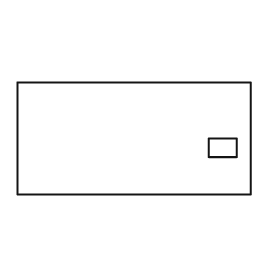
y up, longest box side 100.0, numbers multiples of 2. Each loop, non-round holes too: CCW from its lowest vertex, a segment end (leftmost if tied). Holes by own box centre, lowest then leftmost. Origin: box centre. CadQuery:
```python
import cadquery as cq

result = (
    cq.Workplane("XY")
    .moveTo(-50.0, -24.0)
    .lineTo(50.0, -24.0)
    .lineTo(50.0, 24.0)
    .lineTo(-50.0, 24.0)
    .close()
    .moveTo(32.0, -8.0)
    .lineTo(44.0, -8.0)
    .lineTo(44.0, 0.0)
    .lineTo(32.0, 0.0)
    .close()
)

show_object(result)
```